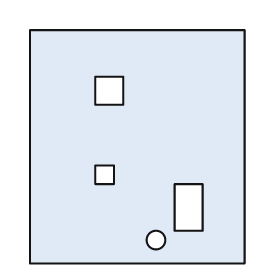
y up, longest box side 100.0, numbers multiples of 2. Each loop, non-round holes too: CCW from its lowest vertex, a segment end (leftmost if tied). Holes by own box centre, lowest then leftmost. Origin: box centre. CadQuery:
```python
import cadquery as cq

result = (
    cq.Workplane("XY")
    .moveTo(-46.0, -50.0)
    .lineTo(46.0, -50.0)
    .lineTo(46.0, 50.0)
    .lineTo(-46.0, 50.0)
    .close()
    .moveTo(8.0, -40.0)
    .circle(4.0)
    .moveTo(16.0, -36.0)
    .lineTo(28.0, -36.0)
    .lineTo(28.0, -16.0)
    .lineTo(16.0, -16.0)
    .close()
    .moveTo(-18.0, -16.0)
    .lineTo(-10.0, -16.0)
    .lineTo(-10.0, -8.0)
    .lineTo(-18.0, -8.0)
    .close()
    .moveTo(-18.0, 18.0)
    .lineTo(-6.0, 18.0)
    .lineTo(-6.0, 30.0)
    .lineTo(-18.0, 30.0)
    .close()
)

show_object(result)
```